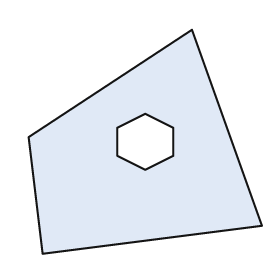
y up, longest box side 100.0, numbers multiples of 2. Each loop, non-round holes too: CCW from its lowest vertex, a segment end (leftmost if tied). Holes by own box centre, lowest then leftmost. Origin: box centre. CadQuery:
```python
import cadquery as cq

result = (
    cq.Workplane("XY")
    .moveTo(-44.0, -48.0)
    .lineTo(50.0, -36.0)
    .lineTo(20.0, 48.0)
    .lineTo(-50.0, 2.0)
    .close()
    .moveTo(0.0, -12.0)
    .lineTo(12.0, -6.0)
    .lineTo(12.0, 6.0)
    .lineTo(0.0, 12.0)
    .lineTo(-12.0, 6.0)
    .lineTo(-12.0, -6.0)
    .close()
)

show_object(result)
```